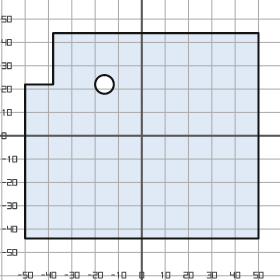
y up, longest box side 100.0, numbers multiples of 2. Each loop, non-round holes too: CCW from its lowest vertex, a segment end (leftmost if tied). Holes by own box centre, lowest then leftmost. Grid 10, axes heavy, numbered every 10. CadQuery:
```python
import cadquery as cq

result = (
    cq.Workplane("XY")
    .moveTo(-50.0, -44.0)
    .lineTo(50.0, -44.0)
    .lineTo(50.0, 44.0)
    .lineTo(-38.0, 44.0)
    .lineTo(-38.0, 22.0)
    .lineTo(-50.0, 22.0)
    .close()
    .moveTo(-16.0, 22.0)
    .circle(4.0)
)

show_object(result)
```